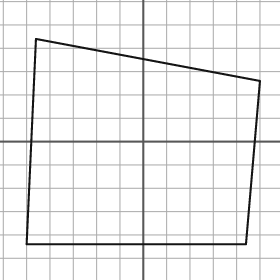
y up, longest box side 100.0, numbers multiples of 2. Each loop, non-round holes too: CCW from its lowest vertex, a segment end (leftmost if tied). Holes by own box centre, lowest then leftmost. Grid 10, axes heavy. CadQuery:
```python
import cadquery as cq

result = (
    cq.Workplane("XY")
    .moveTo(-50.0, -44.0)
    .lineTo(44.0, -44.0)
    .lineTo(50.0, 26.0)
    .lineTo(-46.0, 44.0)
    .close()
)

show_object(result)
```